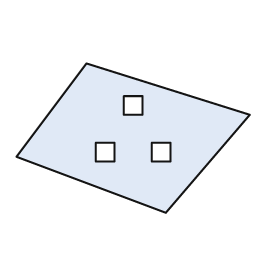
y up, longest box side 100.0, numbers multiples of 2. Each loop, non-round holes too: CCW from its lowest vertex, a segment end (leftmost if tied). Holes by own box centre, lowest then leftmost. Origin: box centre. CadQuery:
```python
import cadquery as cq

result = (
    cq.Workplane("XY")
    .moveTo(14.0, -32.0)
    .lineTo(50.0, 10.0)
    .lineTo(-20.0, 32.0)
    .lineTo(-50.0, -8.0)
    .close()
    .moveTo(-16.0, -10.0)
    .lineTo(-8.0, -10.0)
    .lineTo(-8.0, -2.0)
    .lineTo(-16.0, -2.0)
    .close()
    .moveTo(8.0, -10.0)
    .lineTo(16.0, -10.0)
    .lineTo(16.0, -2.0)
    .lineTo(8.0, -2.0)
    .close()
    .moveTo(-4.0, 10.0)
    .lineTo(4.0, 10.0)
    .lineTo(4.0, 18.0)
    .lineTo(-4.0, 18.0)
    .close()
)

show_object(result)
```